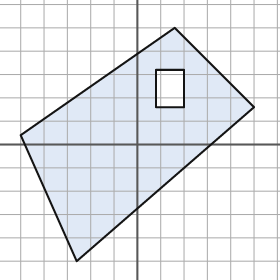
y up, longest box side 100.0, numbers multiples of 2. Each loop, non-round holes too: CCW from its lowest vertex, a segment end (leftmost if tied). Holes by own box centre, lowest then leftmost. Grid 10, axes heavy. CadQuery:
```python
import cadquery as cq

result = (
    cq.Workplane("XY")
    .moveTo(-26.0, -50.0)
    .lineTo(50.0, 16.0)
    .lineTo(16.0, 50.0)
    .lineTo(-50.0, 4.0)
    .close()
    .moveTo(8.0, 16.0)
    .lineTo(20.0, 16.0)
    .lineTo(20.0, 32.0)
    .lineTo(8.0, 32.0)
    .close()
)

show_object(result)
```